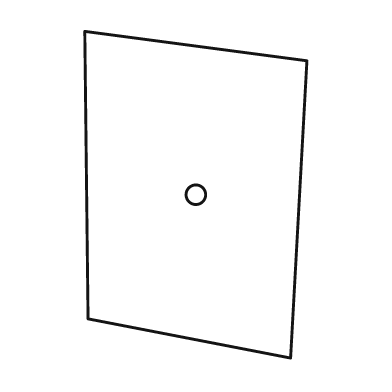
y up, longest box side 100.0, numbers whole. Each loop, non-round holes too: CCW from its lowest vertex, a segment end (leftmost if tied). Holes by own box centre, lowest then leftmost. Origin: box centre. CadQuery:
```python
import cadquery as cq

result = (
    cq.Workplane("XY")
    .moveTo(29.0, -50.0)
    .lineTo(34.0, 41.0)
    .lineTo(-34.0, 50.0)
    .lineTo(-33.0, -38.0)
    .close()
    .moveTo(0.0, 0.0)
    .circle(3.0)
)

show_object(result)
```